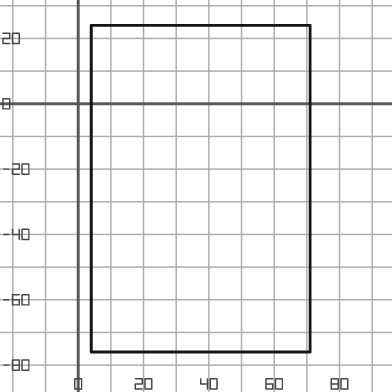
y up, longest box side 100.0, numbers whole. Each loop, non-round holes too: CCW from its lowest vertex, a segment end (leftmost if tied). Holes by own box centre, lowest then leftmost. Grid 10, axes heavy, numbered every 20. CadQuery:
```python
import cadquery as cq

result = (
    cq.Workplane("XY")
    .moveTo(4.0, -76.0)
    .lineTo(71.0, -76.0)
    .lineTo(71.0, 24.0)
    .lineTo(4.0, 24.0)
    .close()
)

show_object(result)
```